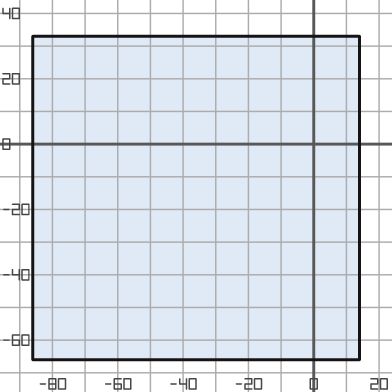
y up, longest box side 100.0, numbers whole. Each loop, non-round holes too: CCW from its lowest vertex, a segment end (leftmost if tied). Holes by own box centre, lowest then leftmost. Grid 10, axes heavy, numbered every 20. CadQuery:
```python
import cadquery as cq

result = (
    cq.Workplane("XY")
    .moveTo(-86.0, -66.0)
    .lineTo(14.0, -66.0)
    .lineTo(14.0, 33.0)
    .lineTo(-86.0, 33.0)
    .close()
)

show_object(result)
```